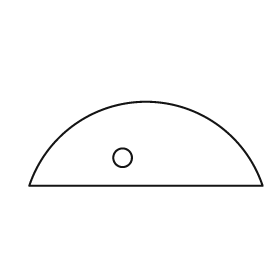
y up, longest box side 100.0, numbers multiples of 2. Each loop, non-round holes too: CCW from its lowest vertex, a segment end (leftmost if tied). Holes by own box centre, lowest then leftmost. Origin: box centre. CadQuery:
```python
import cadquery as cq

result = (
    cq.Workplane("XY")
    .moveTo(-50.0, -18.0)
    .lineTo(50.0, -18.0)
    .threePointArc((0.0, 18.0), (-50.0, -18.0))
    .close()
    .moveTo(-10.0, -6.0)
    .circle(4.0)
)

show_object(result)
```